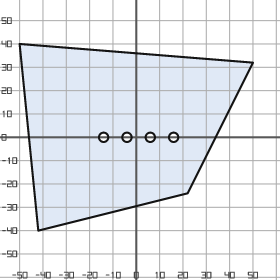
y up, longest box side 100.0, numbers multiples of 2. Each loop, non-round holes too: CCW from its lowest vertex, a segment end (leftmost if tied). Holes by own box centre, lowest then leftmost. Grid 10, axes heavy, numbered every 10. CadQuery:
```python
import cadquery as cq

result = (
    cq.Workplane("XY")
    .moveTo(-42.0, -40.0)
    .lineTo(22.0, -24.0)
    .lineTo(50.0, 32.0)
    .lineTo(-50.0, 40.0)
    .close()
    .moveTo(-14.0, 0.0)
    .circle(2.0)
    .moveTo(-4.0, 0.0)
    .circle(2.0)
    .moveTo(6.0, 0.0)
    .circle(2.0)
    .moveTo(16.0, 0.0)
    .circle(2.0)
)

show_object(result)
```